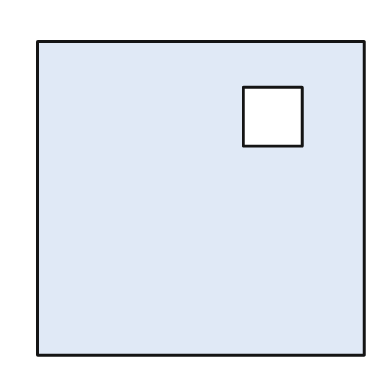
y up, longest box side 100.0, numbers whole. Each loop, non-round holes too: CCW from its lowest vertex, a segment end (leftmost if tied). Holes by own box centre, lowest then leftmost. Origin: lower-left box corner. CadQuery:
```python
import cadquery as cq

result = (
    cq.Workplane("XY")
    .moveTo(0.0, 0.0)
    .lineTo(100.0, 0.0)
    .lineTo(100.0, 96.0)
    .lineTo(0.0, 96.0)
    .close()
    .moveTo(63.0, 64.0)
    .lineTo(81.0, 64.0)
    .lineTo(81.0, 82.0)
    .lineTo(63.0, 82.0)
    .close()
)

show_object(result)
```